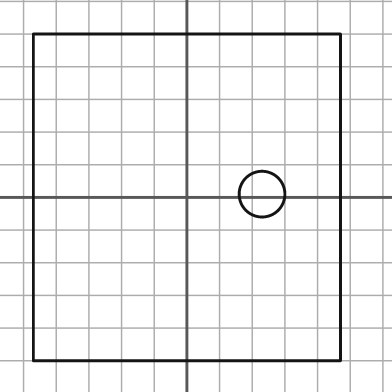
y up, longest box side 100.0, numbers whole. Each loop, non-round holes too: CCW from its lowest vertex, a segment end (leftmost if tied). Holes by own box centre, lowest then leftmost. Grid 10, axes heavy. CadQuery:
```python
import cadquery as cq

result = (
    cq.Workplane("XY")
    .moveTo(-47.0, -50.0)
    .lineTo(47.0, -50.0)
    .lineTo(47.0, 50.0)
    .lineTo(-47.0, 50.0)
    .close()
    .moveTo(23.0, 1.0)
    .circle(7.0)
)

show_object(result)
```